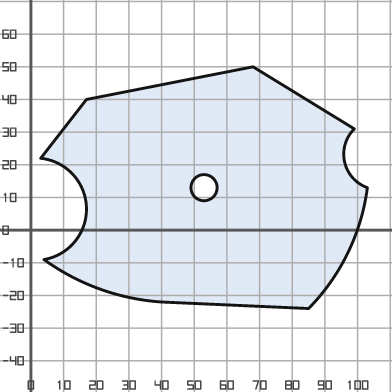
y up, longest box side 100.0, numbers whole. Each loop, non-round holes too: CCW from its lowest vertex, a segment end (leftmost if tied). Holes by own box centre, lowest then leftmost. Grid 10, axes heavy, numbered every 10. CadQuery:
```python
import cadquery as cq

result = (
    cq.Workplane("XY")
    .moveTo(85.0, -24.0)
    .threePointArc((97.0, -7.0), (103.0, 13.0))
    .threePointArc((96.0, 21.0), (99.0, 31.0))
    .lineTo(68.0, 50.0)
    .lineTo(17.0, 40.0)
    .lineTo(3.0, 22.0)
    .threePointArc((17.0, 7.0), (4.0, -9.0))
    .threePointArc((21.0, -18.0), (40.0, -22.0))
    .close()
    .moveTo(53.0, 13.0)
    .circle(4.0)
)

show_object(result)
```